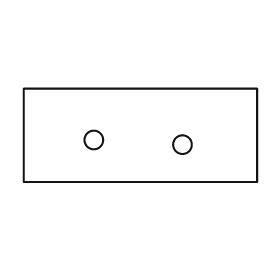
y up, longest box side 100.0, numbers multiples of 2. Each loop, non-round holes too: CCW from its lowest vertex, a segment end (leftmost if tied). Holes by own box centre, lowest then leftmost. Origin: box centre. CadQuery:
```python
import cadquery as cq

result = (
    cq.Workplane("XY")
    .moveTo(-50.0, -20.0)
    .lineTo(50.0, -20.0)
    .lineTo(50.0, 20.0)
    .lineTo(-50.0, 20.0)
    .close()
    .moveTo(18.0, -4.0)
    .circle(4.0)
    .moveTo(-20.0, -2.0)
    .circle(4.0)
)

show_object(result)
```